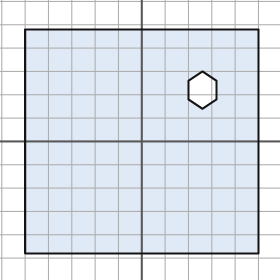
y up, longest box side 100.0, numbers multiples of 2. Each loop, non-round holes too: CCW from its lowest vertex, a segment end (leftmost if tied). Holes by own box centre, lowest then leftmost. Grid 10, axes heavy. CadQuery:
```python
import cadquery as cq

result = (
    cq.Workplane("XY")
    .moveTo(-50.0, -48.0)
    .lineTo(50.0, -48.0)
    .lineTo(50.0, 48.0)
    .lineTo(-50.0, 48.0)
    .close()
    .moveTo(26.0, 14.0)
    .lineTo(32.0, 18.0)
    .lineTo(32.0, 26.0)
    .lineTo(26.0, 30.0)
    .lineTo(20.0, 26.0)
    .lineTo(20.0, 18.0)
    .close()
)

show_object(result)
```